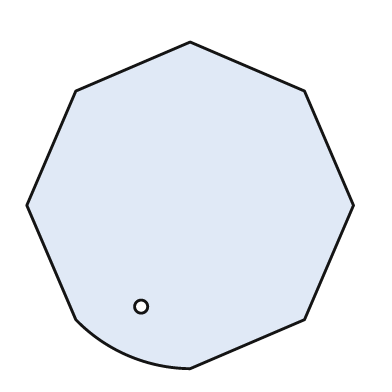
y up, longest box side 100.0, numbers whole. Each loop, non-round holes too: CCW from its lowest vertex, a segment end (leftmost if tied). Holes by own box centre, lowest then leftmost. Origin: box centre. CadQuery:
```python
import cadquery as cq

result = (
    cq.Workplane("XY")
    .moveTo(0.0, -50.0)
    .lineTo(35.0, -35.0)
    .lineTo(50.0, 0.0)
    .lineTo(35.0, 35.0)
    .lineTo(0.0, 50.0)
    .lineTo(-35.0, 35.0)
    .lineTo(-50.0, 0.0)
    .lineTo(-35.0, -35.0)
    .threePointArc((-19.0, -46.0), (0.0, -50.0))
    .close()
    .moveTo(-15.0, -31.0)
    .circle(2.0)
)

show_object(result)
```